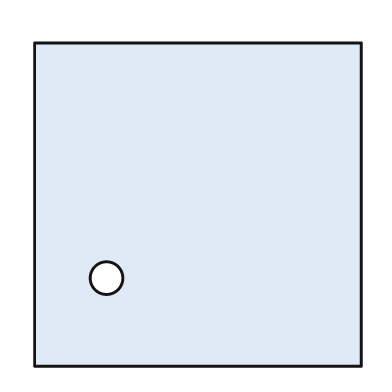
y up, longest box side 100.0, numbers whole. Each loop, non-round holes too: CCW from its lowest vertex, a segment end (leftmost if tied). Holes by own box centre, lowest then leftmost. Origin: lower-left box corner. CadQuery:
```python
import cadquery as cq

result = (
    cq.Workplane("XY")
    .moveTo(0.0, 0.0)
    .lineTo(100.0, 0.0)
    .lineTo(100.0, 99.0)
    .lineTo(0.0, 99.0)
    .close()
    .moveTo(22.0, 27.0)
    .circle(5.0)
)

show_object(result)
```